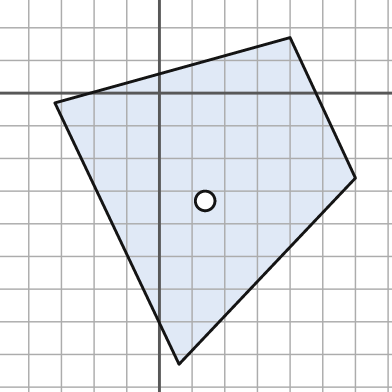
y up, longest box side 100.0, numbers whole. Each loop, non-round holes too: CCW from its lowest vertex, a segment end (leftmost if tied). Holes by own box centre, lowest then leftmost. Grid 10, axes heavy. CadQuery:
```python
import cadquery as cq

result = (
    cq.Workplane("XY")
    .moveTo(6.0, -83.0)
    .lineTo(60.0, -26.0)
    .lineTo(40.0, 17.0)
    .lineTo(-32.0, -3.0)
    .close()
    .moveTo(14.0, -33.0)
    .circle(3.0)
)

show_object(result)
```